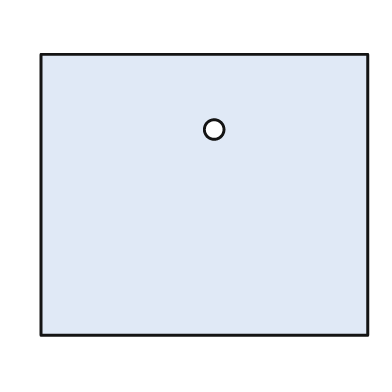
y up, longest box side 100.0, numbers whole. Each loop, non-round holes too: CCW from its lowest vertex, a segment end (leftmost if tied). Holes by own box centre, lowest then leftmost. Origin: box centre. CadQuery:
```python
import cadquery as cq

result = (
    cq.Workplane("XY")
    .moveTo(-50.0, -43.0)
    .lineTo(50.0, -43.0)
    .lineTo(50.0, 43.0)
    .lineTo(-50.0, 43.0)
    .close()
    .moveTo(3.0, 20.0)
    .circle(3.0)
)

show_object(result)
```